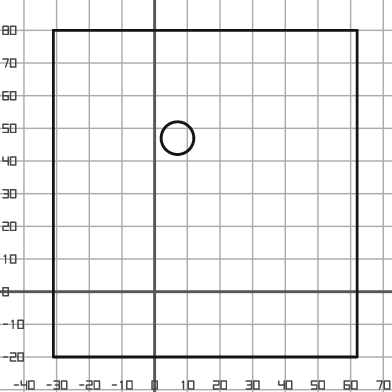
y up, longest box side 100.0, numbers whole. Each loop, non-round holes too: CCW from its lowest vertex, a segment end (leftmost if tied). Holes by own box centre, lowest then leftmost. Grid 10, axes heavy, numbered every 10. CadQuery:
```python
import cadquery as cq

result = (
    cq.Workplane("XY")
    .moveTo(-31.0, -20.0)
    .lineTo(62.0, -20.0)
    .lineTo(62.0, 80.0)
    .lineTo(-31.0, 80.0)
    .close()
    .moveTo(7.0, 47.0)
    .circle(5.0)
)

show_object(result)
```